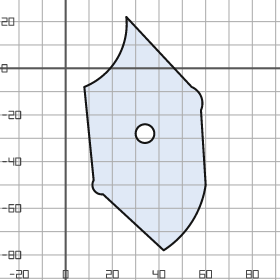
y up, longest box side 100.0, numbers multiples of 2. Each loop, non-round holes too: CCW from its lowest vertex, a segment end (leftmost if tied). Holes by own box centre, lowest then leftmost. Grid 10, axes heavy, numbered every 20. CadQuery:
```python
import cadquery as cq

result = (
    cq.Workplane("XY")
    .moveTo(42.0, -78.0)
    .threePointArc((54.0, -66.0), (60.0, -50.0))
    .lineTo(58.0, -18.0)
    .threePointArc((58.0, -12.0), (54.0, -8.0))
    .lineTo(26.0, 22.0)
    .threePointArc((22.0, 4.0), (8.0, -8.0))
    .lineTo(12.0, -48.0)
    .threePointArc((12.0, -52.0), (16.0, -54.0))
    .close()
    .moveTo(34.0, -28.0)
    .circle(4.0)
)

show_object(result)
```